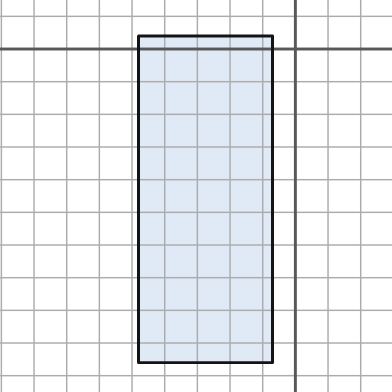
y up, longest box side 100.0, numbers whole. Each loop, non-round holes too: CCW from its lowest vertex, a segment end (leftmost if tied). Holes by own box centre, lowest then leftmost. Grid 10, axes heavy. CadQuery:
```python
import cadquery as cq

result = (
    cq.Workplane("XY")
    .moveTo(-48.0, -96.0)
    .lineTo(-7.0, -96.0)
    .lineTo(-7.0, 4.0)
    .lineTo(-48.0, 4.0)
    .close()
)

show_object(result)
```